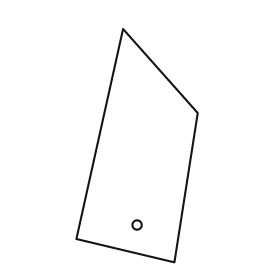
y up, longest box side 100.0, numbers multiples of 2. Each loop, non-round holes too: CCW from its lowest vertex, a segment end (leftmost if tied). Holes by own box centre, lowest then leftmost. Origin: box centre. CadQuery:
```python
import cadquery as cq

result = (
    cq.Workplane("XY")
    .moveTo(16.0, -50.0)
    .lineTo(26.0, 14.0)
    .lineTo(-6.0, 50.0)
    .lineTo(-26.0, -40.0)
    .close()
    .moveTo(0.0, -34.0)
    .circle(2.0)
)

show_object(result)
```